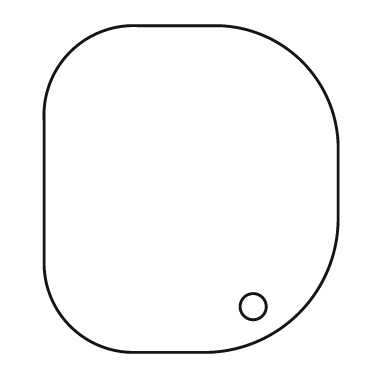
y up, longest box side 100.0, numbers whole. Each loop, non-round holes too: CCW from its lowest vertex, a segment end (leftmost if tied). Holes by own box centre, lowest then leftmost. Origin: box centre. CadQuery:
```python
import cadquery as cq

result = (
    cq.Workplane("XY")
    .moveTo(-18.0, -50.0)
    .lineTo(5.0, -50.0)
    .threePointArc((33.0, -38.0), (45.0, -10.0))
    .lineTo(45.0, 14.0)
    .threePointArc((34.0, 39.0), (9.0, 50.0))
    .lineTo(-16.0, 50.0)
    .threePointArc((-37.0, 42.0), (-45.0, 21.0))
    .lineTo(-45.0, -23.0)
    .threePointArc((-37.0, -42.0), (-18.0, -50.0))
    .close()
    .moveTo(19.0, -36.0)
    .circle(4.0)
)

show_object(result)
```